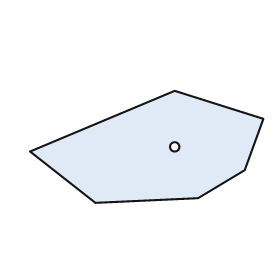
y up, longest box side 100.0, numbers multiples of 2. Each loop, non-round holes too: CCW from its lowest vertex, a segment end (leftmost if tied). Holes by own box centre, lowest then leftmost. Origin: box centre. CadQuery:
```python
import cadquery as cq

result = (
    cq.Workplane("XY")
    .moveTo(-22.0, -24.0)
    .lineTo(22.0, -22.0)
    .lineTo(42.0, -10.0)
    .lineTo(50.0, 12.0)
    .lineTo(12.0, 24.0)
    .lineTo(-50.0, -2.0)
    .close()
    .moveTo(12.0, 0.0)
    .circle(2.0)
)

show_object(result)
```